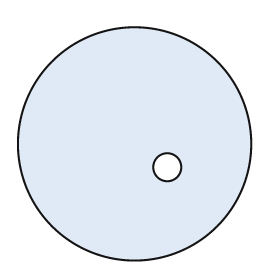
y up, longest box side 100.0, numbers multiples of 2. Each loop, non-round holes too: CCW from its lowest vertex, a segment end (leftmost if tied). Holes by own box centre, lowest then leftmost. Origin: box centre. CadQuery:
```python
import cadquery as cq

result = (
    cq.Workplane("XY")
    .moveTo(0.0, 0.0)
    .circle(50.0)
    .moveTo(14.0, -10.0)
    .circle(6.0)
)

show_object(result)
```